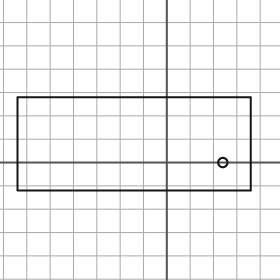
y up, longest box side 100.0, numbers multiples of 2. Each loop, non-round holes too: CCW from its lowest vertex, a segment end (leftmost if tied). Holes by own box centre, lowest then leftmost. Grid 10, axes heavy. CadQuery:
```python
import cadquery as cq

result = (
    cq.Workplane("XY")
    .moveTo(-64.0, -12.0)
    .lineTo(36.0, -12.0)
    .lineTo(36.0, 28.0)
    .lineTo(-64.0, 28.0)
    .close()
    .moveTo(24.0, 0.0)
    .circle(2.0)
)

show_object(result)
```